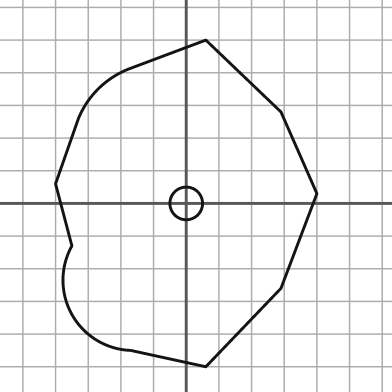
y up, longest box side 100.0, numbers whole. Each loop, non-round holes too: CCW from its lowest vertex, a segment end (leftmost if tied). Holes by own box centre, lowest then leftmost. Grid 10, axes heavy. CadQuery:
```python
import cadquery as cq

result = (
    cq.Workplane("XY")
    .moveTo(6.0, -50.0)
    .lineTo(29.0, -26.0)
    .lineTo(40.0, 3.0)
    .lineTo(29.0, 28.0)
    .lineTo(6.0, 50.0)
    .lineTo(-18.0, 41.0)
    .threePointArc((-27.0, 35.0), (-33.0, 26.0))
    .lineTo(-40.0, 6.0)
    .lineTo(-35.0, -13.0)
    .threePointArc((-35.0, -34.0), (-17.0, -45.0))
    .close()
    .moveTo(0.0, 0.0)
    .circle(5.0)
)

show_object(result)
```